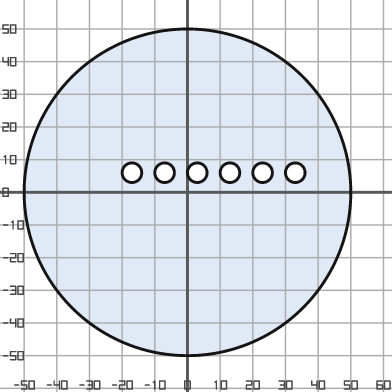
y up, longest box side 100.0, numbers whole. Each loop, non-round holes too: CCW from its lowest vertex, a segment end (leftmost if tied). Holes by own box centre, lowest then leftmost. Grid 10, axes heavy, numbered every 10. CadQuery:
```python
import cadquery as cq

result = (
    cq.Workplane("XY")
    .moveTo(0.0, 0.0)
    .circle(50.0)
    .moveTo(-17.0, 6.0)
    .circle(3.0)
    .moveTo(-7.0, 6.0)
    .circle(3.0)
    .moveTo(3.0, 6.0)
    .circle(3.0)
    .moveTo(13.0, 6.0)
    .circle(3.0)
    .moveTo(23.0, 6.0)
    .circle(3.0)
    .moveTo(33.0, 6.0)
    .circle(3.0)
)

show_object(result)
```